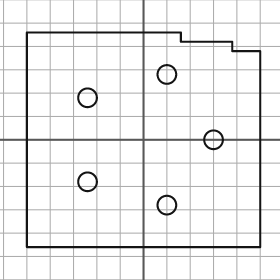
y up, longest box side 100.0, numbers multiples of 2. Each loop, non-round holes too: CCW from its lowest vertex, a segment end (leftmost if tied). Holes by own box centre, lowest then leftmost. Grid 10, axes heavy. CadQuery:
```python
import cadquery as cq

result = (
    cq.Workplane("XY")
    .moveTo(-50.0, -46.0)
    .lineTo(50.0, -46.0)
    .lineTo(50.0, 38.0)
    .lineTo(38.0, 38.0)
    .lineTo(38.0, 42.0)
    .lineTo(16.0, 42.0)
    .lineTo(16.0, 46.0)
    .lineTo(-50.0, 46.0)
    .close()
    .moveTo(10.0, -28.0)
    .circle(4.0)
    .moveTo(-24.0, -18.0)
    .circle(4.0)
    .moveTo(30.0, 0.0)
    .circle(4.0)
    .moveTo(-24.0, 18.0)
    .circle(4.0)
    .moveTo(10.0, 28.0)
    .circle(4.0)
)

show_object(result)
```